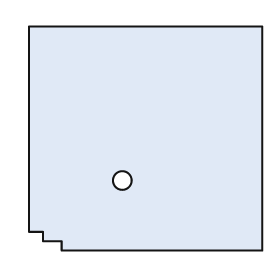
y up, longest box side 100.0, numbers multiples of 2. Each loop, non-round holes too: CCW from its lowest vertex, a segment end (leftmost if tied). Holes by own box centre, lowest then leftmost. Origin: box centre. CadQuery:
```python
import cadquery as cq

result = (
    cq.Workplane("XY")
    .moveTo(-36.0, -48.0)
    .lineTo(50.0, -48.0)
    .lineTo(50.0, 48.0)
    .lineTo(-50.0, 48.0)
    .lineTo(-50.0, -40.0)
    .lineTo(-44.0, -40.0)
    .lineTo(-44.0, -44.0)
    .lineTo(-36.0, -44.0)
    .close()
    .moveTo(-10.0, -18.0)
    .circle(4.0)
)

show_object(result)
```